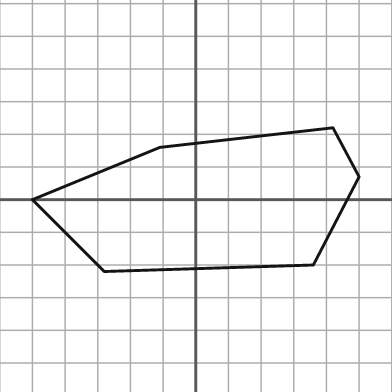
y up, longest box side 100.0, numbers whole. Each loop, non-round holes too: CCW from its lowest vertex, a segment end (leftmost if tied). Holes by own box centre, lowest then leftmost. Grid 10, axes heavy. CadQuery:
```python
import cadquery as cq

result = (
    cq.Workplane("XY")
    .moveTo(-28.0, -22.0)
    .lineTo(36.0, -20.0)
    .lineTo(50.0, 7.0)
    .lineTo(42.0, 22.0)
    .lineTo(-11.0, 16.0)
    .lineTo(-50.0, 0.0)
    .close()
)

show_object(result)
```